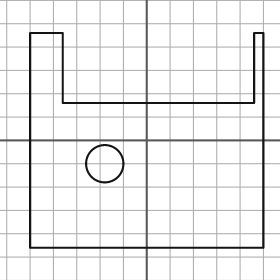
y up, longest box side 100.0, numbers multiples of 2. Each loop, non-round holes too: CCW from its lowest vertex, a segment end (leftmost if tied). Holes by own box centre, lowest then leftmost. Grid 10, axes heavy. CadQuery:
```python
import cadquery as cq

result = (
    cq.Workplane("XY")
    .moveTo(-50.0, -46.0)
    .lineTo(50.0, -46.0)
    .lineTo(50.0, 46.0)
    .lineTo(46.0, 46.0)
    .lineTo(46.0, 16.0)
    .lineTo(-36.0, 16.0)
    .lineTo(-36.0, 46.0)
    .lineTo(-50.0, 46.0)
    .close()
    .moveTo(-18.0, -10.0)
    .circle(8.0)
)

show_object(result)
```